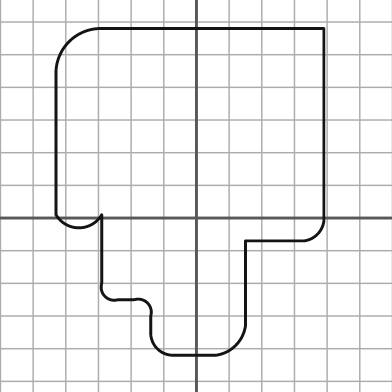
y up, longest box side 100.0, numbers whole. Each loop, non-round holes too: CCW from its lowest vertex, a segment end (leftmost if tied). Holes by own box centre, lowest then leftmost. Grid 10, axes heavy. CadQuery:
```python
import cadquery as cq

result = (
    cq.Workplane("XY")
    .moveTo(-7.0, -42.0)
    .lineTo(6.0, -42.0)
    .threePointArc((12.0, -39.0), (15.0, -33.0))
    .lineTo(15.0, -7.0)
    .lineTo(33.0, -7.0)
    .threePointArc((37.0, -5.0), (39.0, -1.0))
    .lineTo(39.0, 58.0)
    .lineTo(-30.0, 58.0)
    .threePointArc((-39.0, 54.0), (-43.0, 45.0))
    .lineTo(-43.0, 1.0)
    .threePointArc((-36.0, -3.0), (-29.0, 1.0))
    .lineTo(-29.0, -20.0)
    .threePointArc((-28.0, -24.0), (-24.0, -25.0))
    .lineTo(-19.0, -25.0)
    .threePointArc((-15.0, -26.0), (-14.0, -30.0))
    .lineTo(-14.0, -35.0)
    .threePointArc((-12.0, -40.0), (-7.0, -42.0))
    .close()
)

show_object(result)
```